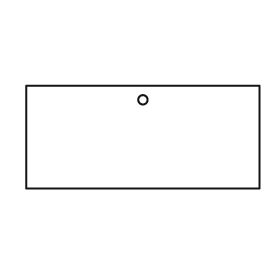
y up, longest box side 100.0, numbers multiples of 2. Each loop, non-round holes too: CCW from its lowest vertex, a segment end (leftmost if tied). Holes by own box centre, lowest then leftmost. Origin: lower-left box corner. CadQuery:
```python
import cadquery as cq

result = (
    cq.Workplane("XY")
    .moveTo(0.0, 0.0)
    .lineTo(100.0, 0.0)
    .lineTo(100.0, 44.0)
    .lineTo(0.0, 44.0)
    .close()
    .moveTo(50.0, 38.0)
    .circle(2.0)
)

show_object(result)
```